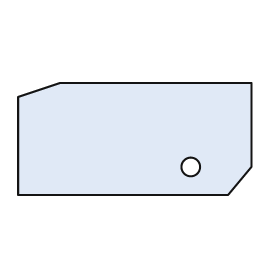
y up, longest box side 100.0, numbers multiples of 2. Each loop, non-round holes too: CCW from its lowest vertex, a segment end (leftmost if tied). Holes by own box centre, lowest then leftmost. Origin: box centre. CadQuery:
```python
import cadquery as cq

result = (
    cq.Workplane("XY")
    .moveTo(-50.0, -24.0)
    .lineTo(40.0, -24.0)
    .lineTo(50.0, -12.0)
    .lineTo(50.0, 24.0)
    .lineTo(-32.0, 24.0)
    .lineTo(-50.0, 18.0)
    .close()
    .moveTo(24.0, -12.0)
    .circle(4.0)
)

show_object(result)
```